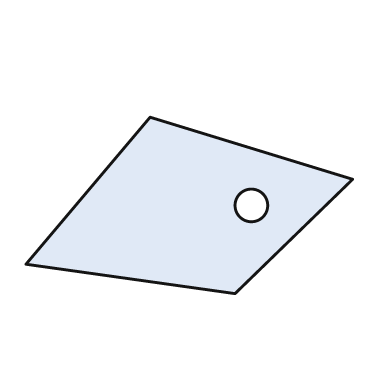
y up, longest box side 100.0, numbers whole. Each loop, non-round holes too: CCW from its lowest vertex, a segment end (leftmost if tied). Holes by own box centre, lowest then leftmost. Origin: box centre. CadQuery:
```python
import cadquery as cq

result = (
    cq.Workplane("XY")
    .moveTo(14.0, -27.0)
    .lineTo(50.0, 8.0)
    .lineTo(-12.0, 27.0)
    .lineTo(-50.0, -18.0)
    .close()
    .moveTo(19.0, 0.0)
    .circle(5.0)
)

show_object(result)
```